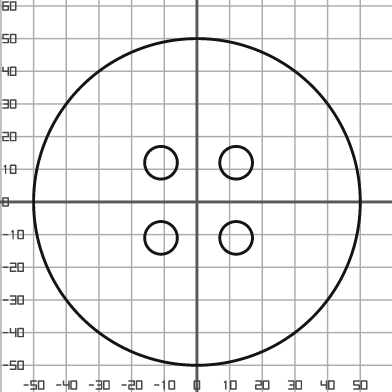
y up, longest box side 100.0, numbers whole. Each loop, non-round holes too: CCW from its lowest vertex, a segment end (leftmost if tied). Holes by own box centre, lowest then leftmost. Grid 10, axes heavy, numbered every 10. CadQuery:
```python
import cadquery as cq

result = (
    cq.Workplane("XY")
    .moveTo(0.0, 0.0)
    .circle(50.0)
    .moveTo(-11.0, -11.0)
    .circle(5.0)
    .moveTo(12.0, -11.0)
    .circle(5.0)
    .moveTo(-11.0, 12.0)
    .circle(5.0)
    .moveTo(12.0, 12.0)
    .circle(5.0)
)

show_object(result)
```